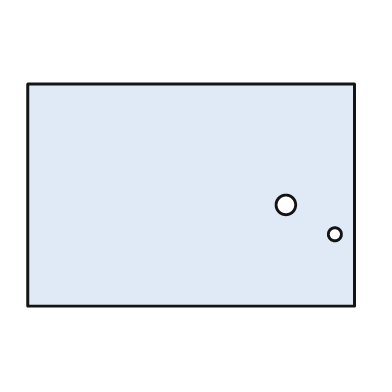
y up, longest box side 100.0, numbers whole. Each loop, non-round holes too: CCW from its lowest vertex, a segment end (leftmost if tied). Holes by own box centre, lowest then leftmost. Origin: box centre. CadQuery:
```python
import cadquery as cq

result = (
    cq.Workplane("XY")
    .moveTo(-50.0, -34.0)
    .lineTo(50.0, -34.0)
    .lineTo(50.0, 34.0)
    .lineTo(-50.0, 34.0)
    .close()
    .moveTo(44.0, -12.0)
    .circle(2.0)
    .moveTo(29.0, -3.0)
    .circle(3.0)
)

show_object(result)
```